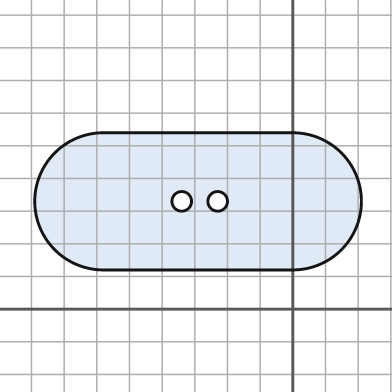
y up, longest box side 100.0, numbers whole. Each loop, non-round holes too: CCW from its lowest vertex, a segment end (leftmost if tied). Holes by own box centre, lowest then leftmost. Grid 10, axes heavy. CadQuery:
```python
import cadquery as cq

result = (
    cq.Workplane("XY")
    .moveTo(-58.0, 12.0)
    .lineTo(0.0, 12.0)
    .threePointArc((21.0, 33.0), (0.0, 54.0))
    .lineTo(-58.0, 54.0)
    .threePointArc((-79.0, 33.0), (-58.0, 12.0))
    .close()
    .moveTo(-34.0, 33.0)
    .circle(3.0)
    .moveTo(-23.0, 33.0)
    .circle(3.0)
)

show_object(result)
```